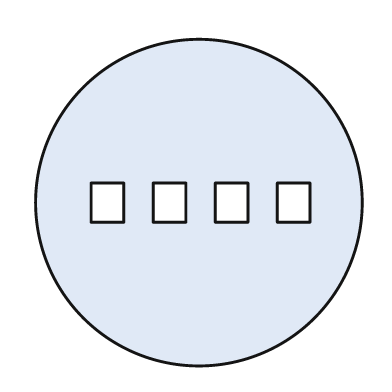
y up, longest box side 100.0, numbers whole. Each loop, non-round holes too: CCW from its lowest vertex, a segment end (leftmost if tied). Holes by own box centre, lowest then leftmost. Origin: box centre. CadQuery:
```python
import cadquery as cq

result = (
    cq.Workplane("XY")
    .moveTo(0.0, 0.0)
    .circle(50.0)
    .moveTo(-33.0, -6.0)
    .lineTo(-23.0, -6.0)
    .lineTo(-23.0, 6.0)
    .lineTo(-33.0, 6.0)
    .close()
    .moveTo(-14.0, -6.0)
    .lineTo(-4.0, -6.0)
    .lineTo(-4.0, 6.0)
    .lineTo(-14.0, 6.0)
    .close()
    .moveTo(5.0, -6.0)
    .lineTo(15.0, -6.0)
    .lineTo(15.0, 6.0)
    .lineTo(5.0, 6.0)
    .close()
    .moveTo(24.0, -6.0)
    .lineTo(34.0, -6.0)
    .lineTo(34.0, 6.0)
    .lineTo(24.0, 6.0)
    .close()
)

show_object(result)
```